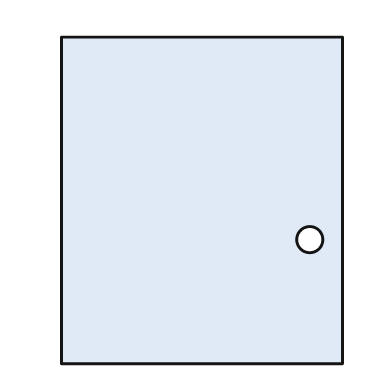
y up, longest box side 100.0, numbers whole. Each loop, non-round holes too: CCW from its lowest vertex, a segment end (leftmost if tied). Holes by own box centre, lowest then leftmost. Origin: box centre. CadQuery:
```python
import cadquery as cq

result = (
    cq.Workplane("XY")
    .moveTo(-43.0, -50.0)
    .lineTo(43.0, -50.0)
    .lineTo(43.0, 50.0)
    .lineTo(-43.0, 50.0)
    .close()
    .moveTo(33.0, -12.0)
    .circle(4.0)
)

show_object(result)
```